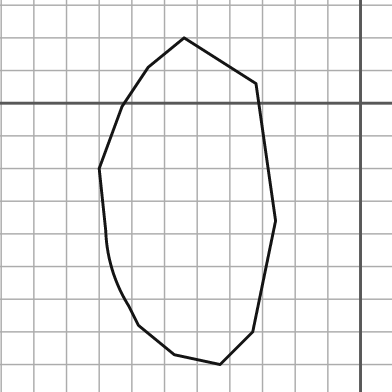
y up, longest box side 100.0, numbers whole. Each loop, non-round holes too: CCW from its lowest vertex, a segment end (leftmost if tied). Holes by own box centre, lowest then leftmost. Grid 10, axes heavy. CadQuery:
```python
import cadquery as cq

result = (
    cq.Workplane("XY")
    .moveTo(-43.0, -80.0)
    .lineTo(-33.0, -70.0)
    .lineTo(-26.0, -36.0)
    .lineTo(-32.0, 6.0)
    .lineTo(-54.0, 20.0)
    .lineTo(-65.0, 11.0)
    .lineTo(-73.0, -1.0)
    .lineTo(-80.0, -20.0)
    .lineTo(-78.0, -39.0)
    .threePointArc((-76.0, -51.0), (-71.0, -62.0))
    .lineTo(-68.0, -68.0)
    .lineTo(-57.0, -77.0)
    .close()
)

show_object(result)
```